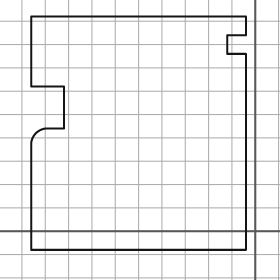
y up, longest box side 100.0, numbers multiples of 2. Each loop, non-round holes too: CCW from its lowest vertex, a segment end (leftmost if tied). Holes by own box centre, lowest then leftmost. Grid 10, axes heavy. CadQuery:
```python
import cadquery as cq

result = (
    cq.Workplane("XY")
    .moveTo(-96.0, -8.0)
    .lineTo(-4.0, -8.0)
    .lineTo(-4.0, 76.0)
    .lineTo(-12.0, 76.0)
    .lineTo(-12.0, 84.0)
    .lineTo(-4.0, 84.0)
    .lineTo(-4.0, 92.0)
    .lineTo(-96.0, 92.0)
    .lineTo(-96.0, 62.0)
    .lineTo(-82.0, 62.0)
    .lineTo(-82.0, 44.0)
    .lineTo(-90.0, 44.0)
    .threePointArc((-94.0, 42.0), (-96.0, 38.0))
    .close()
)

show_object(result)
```